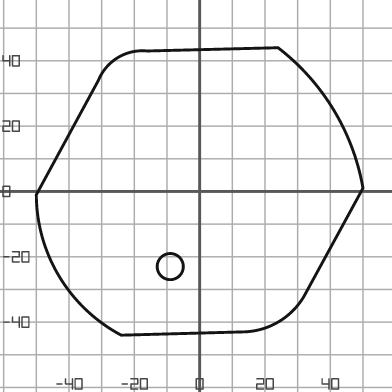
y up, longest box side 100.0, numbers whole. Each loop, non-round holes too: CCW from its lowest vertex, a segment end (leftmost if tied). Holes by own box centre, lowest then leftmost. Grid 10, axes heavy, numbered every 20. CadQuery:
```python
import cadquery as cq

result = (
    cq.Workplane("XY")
    .moveTo(-24.0, -44.0)
    .lineTo(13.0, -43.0)
    .threePointArc((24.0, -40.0), (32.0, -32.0))
    .lineTo(50.0, 1.0)
    .threePointArc((41.0, 25.0), (24.0, 44.0))
    .lineTo(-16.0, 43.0)
    .threePointArc((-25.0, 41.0), (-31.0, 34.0))
    .lineTo(-50.0, -1.0)
    .threePointArc((-43.0, -26.0), (-24.0, -44.0))
    .close()
    .moveTo(-9.0, -23.0)
    .circle(4.0)
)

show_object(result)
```